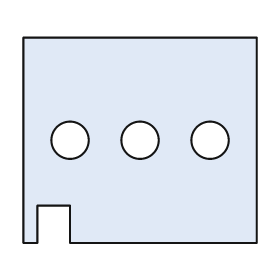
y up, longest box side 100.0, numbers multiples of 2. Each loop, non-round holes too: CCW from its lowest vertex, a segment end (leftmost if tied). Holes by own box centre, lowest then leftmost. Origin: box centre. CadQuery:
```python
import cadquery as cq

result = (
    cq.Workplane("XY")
    .moveTo(-50.0, -44.0)
    .lineTo(-44.0, -44.0)
    .lineTo(-44.0, -28.0)
    .lineTo(-30.0, -28.0)
    .lineTo(-30.0, -44.0)
    .lineTo(50.0, -44.0)
    .lineTo(50.0, 44.0)
    .lineTo(-50.0, 44.0)
    .close()
    .moveTo(-30.0, 0.0)
    .circle(8.0)
    .moveTo(0.0, 0.0)
    .circle(8.0)
    .moveTo(30.0, 0.0)
    .circle(8.0)
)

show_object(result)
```